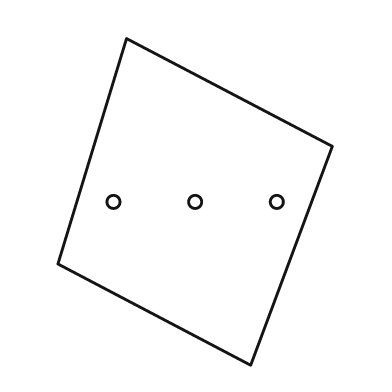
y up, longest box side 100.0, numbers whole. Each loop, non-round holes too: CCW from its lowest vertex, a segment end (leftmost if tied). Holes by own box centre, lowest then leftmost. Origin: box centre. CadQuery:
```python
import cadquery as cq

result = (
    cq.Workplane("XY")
    .moveTo(17.0, -50.0)
    .lineTo(42.0, 17.0)
    .lineTo(-21.0, 50.0)
    .lineTo(-42.0, -19.0)
    .close()
    .moveTo(-25.0, 0.0)
    .circle(2.0)
    .moveTo(0.0, 0.0)
    .circle(2.0)
    .moveTo(25.0, 0.0)
    .circle(2.0)
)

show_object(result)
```